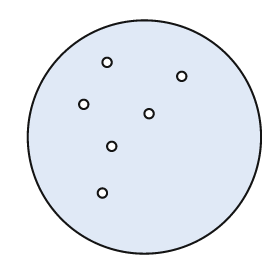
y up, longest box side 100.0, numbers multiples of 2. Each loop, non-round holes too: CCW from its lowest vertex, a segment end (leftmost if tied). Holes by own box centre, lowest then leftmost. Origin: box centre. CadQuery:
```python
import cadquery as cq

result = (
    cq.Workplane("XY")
    .moveTo(0.0, 0.0)
    .circle(50.0)
    .moveTo(-18.0, -24.0)
    .circle(2.0)
    .moveTo(-14.0, -4.0)
    .circle(2.0)
    .moveTo(2.0, 10.0)
    .circle(2.0)
    .moveTo(-26.0, 14.0)
    .circle(2.0)
    .moveTo(16.0, 26.0)
    .circle(2.0)
    .moveTo(-16.0, 32.0)
    .circle(2.0)
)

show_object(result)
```